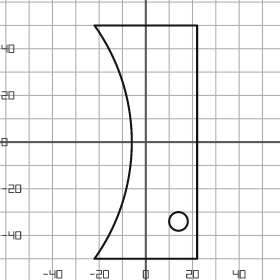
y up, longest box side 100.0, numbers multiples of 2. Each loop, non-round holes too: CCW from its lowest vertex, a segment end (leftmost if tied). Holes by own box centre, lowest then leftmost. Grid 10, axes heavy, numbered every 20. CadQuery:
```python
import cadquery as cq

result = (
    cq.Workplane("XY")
    .moveTo(-22.0, -50.0)
    .lineTo(22.0, -50.0)
    .lineTo(22.0, 50.0)
    .lineTo(-22.0, 50.0)
    .threePointArc((-6.0, 0.0), (-22.0, -50.0))
    .close()
    .moveTo(14.0, -34.0)
    .circle(4.0)
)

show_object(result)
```